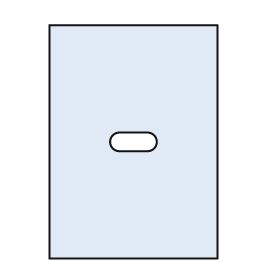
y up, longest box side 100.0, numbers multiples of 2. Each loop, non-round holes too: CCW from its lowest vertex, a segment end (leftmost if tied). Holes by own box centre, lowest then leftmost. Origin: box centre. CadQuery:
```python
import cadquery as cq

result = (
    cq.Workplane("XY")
    .moveTo(-36.0, -50.0)
    .lineTo(36.0, -50.0)
    .lineTo(36.0, 50.0)
    .lineTo(-36.0, 50.0)
    .close()
    .moveTo(-6.0, -4.0)
    .lineTo(6.0, -4.0)
    .threePointArc((10.0, 0.0), (6.0, 4.0))
    .lineTo(-6.0, 4.0)
    .threePointArc((-10.0, 0.0), (-6.0, -4.0))
    .close()
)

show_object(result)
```